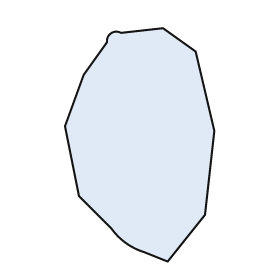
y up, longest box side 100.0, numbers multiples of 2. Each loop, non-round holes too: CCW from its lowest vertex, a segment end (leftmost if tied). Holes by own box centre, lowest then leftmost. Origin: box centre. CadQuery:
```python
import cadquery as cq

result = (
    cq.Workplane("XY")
    .moveTo(12.0, -50.0)
    .lineTo(28.0, -30.0)
    .lineTo(32.0, 6.0)
    .lineTo(24.0, 40.0)
    .lineTo(10.0, 50.0)
    .lineTo(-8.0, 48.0)
    .threePointArc((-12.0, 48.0), (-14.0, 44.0))
    .lineTo(-24.0, 30.0)
    .lineTo(-32.0, 8.0)
    .lineTo(-26.0, -22.0)
    .lineTo(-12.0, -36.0)
    .threePointArc((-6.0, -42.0), (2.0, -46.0))
    .close()
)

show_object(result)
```